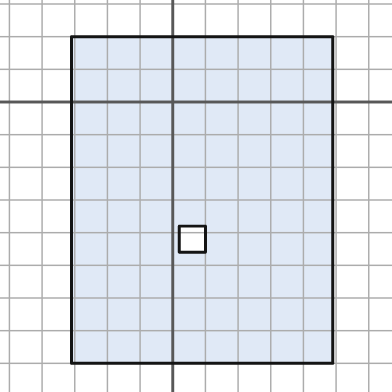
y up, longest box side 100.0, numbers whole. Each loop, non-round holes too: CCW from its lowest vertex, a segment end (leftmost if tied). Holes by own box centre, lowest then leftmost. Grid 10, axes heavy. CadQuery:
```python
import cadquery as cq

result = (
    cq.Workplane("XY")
    .moveTo(-31.0, -80.0)
    .lineTo(49.0, -80.0)
    .lineTo(49.0, 20.0)
    .lineTo(-31.0, 20.0)
    .close()
    .moveTo(2.0, -46.0)
    .lineTo(10.0, -46.0)
    .lineTo(10.0, -38.0)
    .lineTo(2.0, -38.0)
    .close()
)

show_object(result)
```